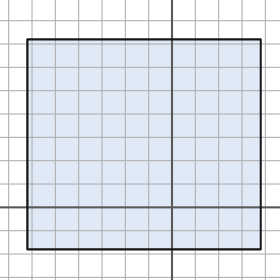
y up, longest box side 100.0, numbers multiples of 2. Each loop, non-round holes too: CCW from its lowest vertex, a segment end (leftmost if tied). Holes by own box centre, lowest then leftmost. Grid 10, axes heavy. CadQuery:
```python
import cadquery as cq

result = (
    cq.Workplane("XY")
    .moveTo(-62.0, -18.0)
    .lineTo(38.0, -18.0)
    .lineTo(38.0, 72.0)
    .lineTo(-62.0, 72.0)
    .close()
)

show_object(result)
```